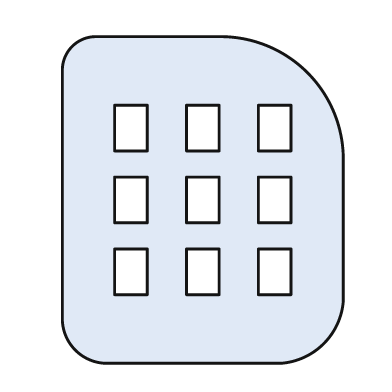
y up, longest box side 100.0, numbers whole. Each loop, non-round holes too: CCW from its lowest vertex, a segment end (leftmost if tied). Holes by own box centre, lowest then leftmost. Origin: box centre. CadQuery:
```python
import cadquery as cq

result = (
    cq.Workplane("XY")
    .moveTo(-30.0, -50.0)
    .lineTo(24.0, -50.0)
    .threePointArc((37.0, -44.0), (43.0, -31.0))
    .lineTo(43.0, 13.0)
    .threePointArc((32.0, 39.0), (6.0, 50.0))
    .lineTo(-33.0, 50.0)
    .threePointArc((-40.0, 47.0), (-43.0, 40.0))
    .lineTo(-43.0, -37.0)
    .threePointArc((-39.0, -46.0), (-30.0, -50.0))
    .close()
    .moveTo(-27.0, -29.0)
    .lineTo(-17.0, -29.0)
    .lineTo(-17.0, -15.0)
    .lineTo(-27.0, -15.0)
    .close()
    .moveTo(-5.0, -29.0)
    .lineTo(5.0, -29.0)
    .lineTo(5.0, -15.0)
    .lineTo(-5.0, -15.0)
    .close()
    .moveTo(17.0, -29.0)
    .lineTo(27.0, -29.0)
    .lineTo(27.0, -15.0)
    .lineTo(17.0, -15.0)
    .close()
    .moveTo(-27.0, -7.0)
    .lineTo(-17.0, -7.0)
    .lineTo(-17.0, 7.0)
    .lineTo(-27.0, 7.0)
    .close()
    .moveTo(-5.0, -7.0)
    .lineTo(5.0, -7.0)
    .lineTo(5.0, 7.0)
    .lineTo(-5.0, 7.0)
    .close()
    .moveTo(17.0, -7.0)
    .lineTo(27.0, -7.0)
    .lineTo(27.0, 7.0)
    .lineTo(17.0, 7.0)
    .close()
    .moveTo(-27.0, 15.0)
    .lineTo(-17.0, 15.0)
    .lineTo(-17.0, 29.0)
    .lineTo(-27.0, 29.0)
    .close()
    .moveTo(-5.0, 15.0)
    .lineTo(5.0, 15.0)
    .lineTo(5.0, 29.0)
    .lineTo(-5.0, 29.0)
    .close()
    .moveTo(17.0, 15.0)
    .lineTo(27.0, 15.0)
    .lineTo(27.0, 29.0)
    .lineTo(17.0, 29.0)
    .close()
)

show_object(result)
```